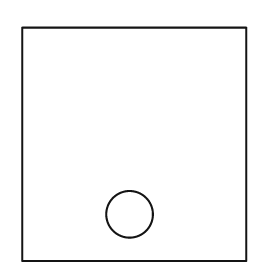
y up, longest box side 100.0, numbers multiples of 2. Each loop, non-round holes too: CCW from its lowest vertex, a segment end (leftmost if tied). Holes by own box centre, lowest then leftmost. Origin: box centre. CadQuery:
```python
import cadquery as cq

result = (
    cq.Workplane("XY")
    .moveTo(-48.0, -50.0)
    .lineTo(48.0, -50.0)
    .lineTo(48.0, 50.0)
    .lineTo(-48.0, 50.0)
    .close()
    .moveTo(-2.0, -30.0)
    .circle(10.0)
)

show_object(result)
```